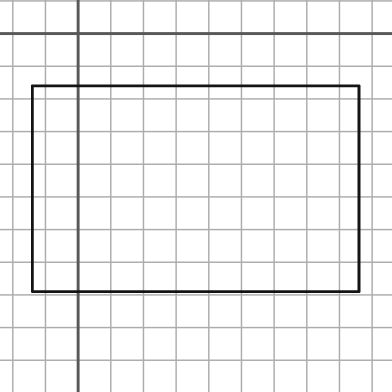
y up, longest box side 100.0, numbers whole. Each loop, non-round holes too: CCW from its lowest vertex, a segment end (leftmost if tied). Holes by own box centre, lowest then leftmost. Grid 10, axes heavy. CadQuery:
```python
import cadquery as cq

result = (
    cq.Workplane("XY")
    .moveTo(-14.0, -79.0)
    .lineTo(86.0, -79.0)
    .lineTo(86.0, -16.0)
    .lineTo(-14.0, -16.0)
    .close()
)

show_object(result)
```